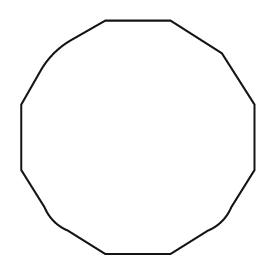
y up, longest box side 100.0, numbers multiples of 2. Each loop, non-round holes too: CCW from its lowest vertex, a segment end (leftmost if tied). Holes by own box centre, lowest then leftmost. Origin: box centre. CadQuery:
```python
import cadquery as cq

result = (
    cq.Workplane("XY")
    .moveTo(-14.0, -50.0)
    .lineTo(14.0, -50.0)
    .lineTo(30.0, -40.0)
    .threePointArc((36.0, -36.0), (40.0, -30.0))
    .lineTo(50.0, -14.0)
    .lineTo(50.0, 14.0)
    .lineTo(36.0, 36.0)
    .lineTo(14.0, 50.0)
    .lineTo(-14.0, 50.0)
    .lineTo(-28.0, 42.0)
    .threePointArc((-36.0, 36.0), (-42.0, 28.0))
    .lineTo(-50.0, 14.0)
    .lineTo(-50.0, -14.0)
    .lineTo(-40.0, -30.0)
    .threePointArc((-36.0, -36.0), (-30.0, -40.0))
    .close()
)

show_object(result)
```